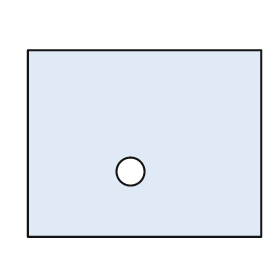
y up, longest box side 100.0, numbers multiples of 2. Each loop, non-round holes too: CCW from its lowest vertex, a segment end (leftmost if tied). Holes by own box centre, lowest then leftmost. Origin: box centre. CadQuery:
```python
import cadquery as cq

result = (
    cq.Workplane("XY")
    .moveTo(-50.0, -40.0)
    .lineTo(50.0, -40.0)
    .lineTo(50.0, 40.0)
    .lineTo(-50.0, 40.0)
    .close()
    .moveTo(-6.0, -12.0)
    .circle(6.0)
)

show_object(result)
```